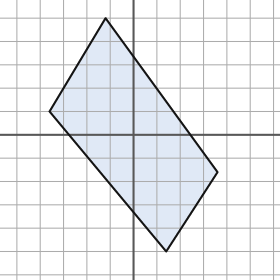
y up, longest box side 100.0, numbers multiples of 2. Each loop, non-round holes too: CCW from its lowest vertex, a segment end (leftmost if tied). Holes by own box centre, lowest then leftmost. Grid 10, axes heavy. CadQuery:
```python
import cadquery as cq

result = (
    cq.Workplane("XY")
    .moveTo(14.0, -50.0)
    .lineTo(36.0, -16.0)
    .lineTo(-12.0, 50.0)
    .lineTo(-36.0, 10.0)
    .close()
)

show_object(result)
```